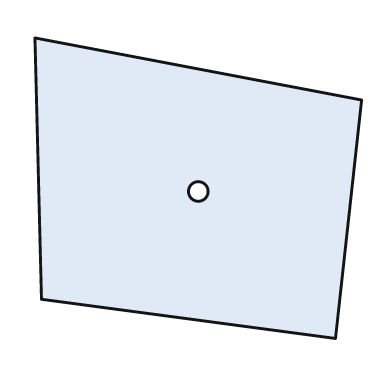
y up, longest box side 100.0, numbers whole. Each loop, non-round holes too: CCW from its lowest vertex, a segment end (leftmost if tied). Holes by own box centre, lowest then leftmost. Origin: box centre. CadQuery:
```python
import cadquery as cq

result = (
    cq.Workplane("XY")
    .moveTo(42.0, -46.0)
    .lineTo(50.0, 27.0)
    .lineTo(-50.0, 46.0)
    .lineTo(-48.0, -34.0)
    .close()
    .moveTo(0.0, -1.0)
    .circle(3.0)
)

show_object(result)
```